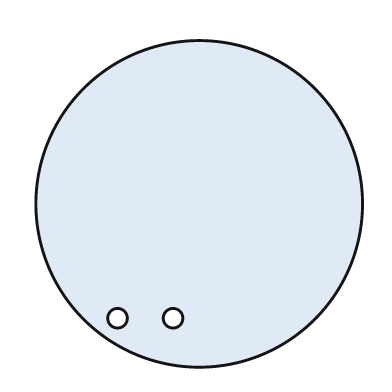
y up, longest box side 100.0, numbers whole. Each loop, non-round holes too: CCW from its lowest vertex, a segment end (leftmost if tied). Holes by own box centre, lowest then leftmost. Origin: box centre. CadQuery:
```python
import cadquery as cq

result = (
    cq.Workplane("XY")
    .moveTo(0.0, 0.0)
    .circle(50.0)
    .moveTo(-25.0, -35.0)
    .circle(3.0)
    .moveTo(-8.0, -35.0)
    .circle(3.0)
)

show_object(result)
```